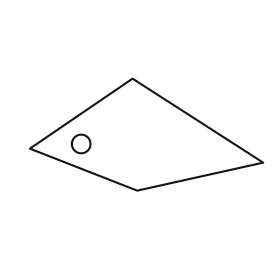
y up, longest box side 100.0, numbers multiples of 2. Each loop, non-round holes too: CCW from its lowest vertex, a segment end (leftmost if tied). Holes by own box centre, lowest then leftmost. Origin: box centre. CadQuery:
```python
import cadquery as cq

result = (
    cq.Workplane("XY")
    .moveTo(-4.0, -24.0)
    .lineTo(50.0, -12.0)
    .lineTo(-6.0, 24.0)
    .lineTo(-50.0, -6.0)
    .close()
    .moveTo(-28.0, -4.0)
    .circle(4.0)
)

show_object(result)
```